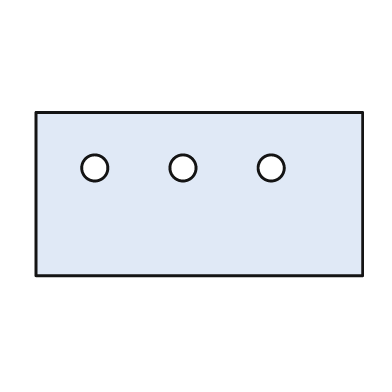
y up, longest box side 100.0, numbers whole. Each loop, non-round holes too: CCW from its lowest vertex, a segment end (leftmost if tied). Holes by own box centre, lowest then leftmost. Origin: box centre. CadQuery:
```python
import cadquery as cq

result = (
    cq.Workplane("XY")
    .moveTo(-50.0, -25.0)
    .lineTo(50.0, -25.0)
    .lineTo(50.0, 25.0)
    .lineTo(-50.0, 25.0)
    .close()
    .moveTo(-32.0, 8.0)
    .circle(4.0)
    .moveTo(-5.0, 8.0)
    .circle(4.0)
    .moveTo(22.0, 8.0)
    .circle(4.0)
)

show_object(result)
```